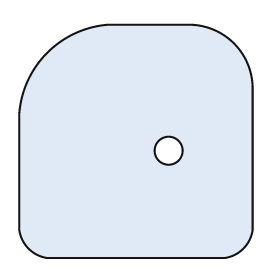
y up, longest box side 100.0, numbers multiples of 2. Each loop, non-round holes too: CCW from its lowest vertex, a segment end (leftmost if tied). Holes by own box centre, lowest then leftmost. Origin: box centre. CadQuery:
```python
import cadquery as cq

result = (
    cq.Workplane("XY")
    .moveTo(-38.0, -50.0)
    .lineTo(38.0, -50.0)
    .threePointArc((46.0, -46.0), (50.0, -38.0))
    .lineTo(50.0, 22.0)
    .threePointArc((42.0, 42.0), (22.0, 50.0))
    .lineTo(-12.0, 50.0)
    .threePointArc((-38.0, 38.0), (-50.0, 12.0))
    .lineTo(-50.0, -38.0)
    .threePointArc((-46.0, -46.0), (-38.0, -50.0))
    .close()
    .moveTo(14.0, -4.0)
    .circle(6.0)
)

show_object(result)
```